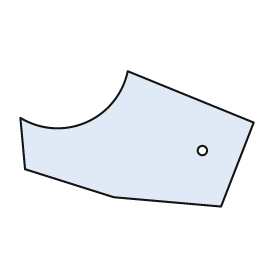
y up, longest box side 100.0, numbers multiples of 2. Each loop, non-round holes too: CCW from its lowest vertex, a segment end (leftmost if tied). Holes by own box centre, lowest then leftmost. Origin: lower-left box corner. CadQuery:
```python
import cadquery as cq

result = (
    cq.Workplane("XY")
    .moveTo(86.0, 0.0)
    .lineTo(100.0, 36.0)
    .lineTo(46.0, 58.0)
    .threePointArc((28.0, 36.0), (0.0, 38.0))
    .lineTo(2.0, 16.0)
    .lineTo(40.0, 4.0)
    .close()
    .moveTo(78.0, 24.0)
    .circle(2.0)
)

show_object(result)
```